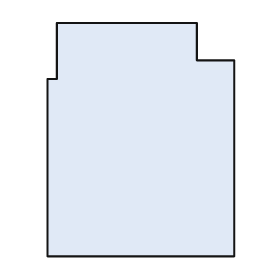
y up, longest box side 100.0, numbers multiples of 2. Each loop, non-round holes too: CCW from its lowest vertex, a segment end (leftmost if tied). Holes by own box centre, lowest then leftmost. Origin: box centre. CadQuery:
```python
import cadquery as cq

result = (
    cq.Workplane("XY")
    .moveTo(-40.0, -50.0)
    .lineTo(40.0, -50.0)
    .lineTo(40.0, 34.0)
    .lineTo(24.0, 34.0)
    .lineTo(24.0, 50.0)
    .lineTo(-36.0, 50.0)
    .lineTo(-36.0, 26.0)
    .lineTo(-40.0, 26.0)
    .close()
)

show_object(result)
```